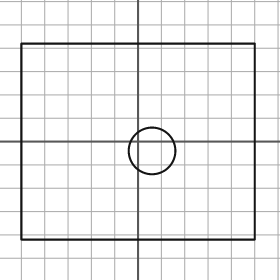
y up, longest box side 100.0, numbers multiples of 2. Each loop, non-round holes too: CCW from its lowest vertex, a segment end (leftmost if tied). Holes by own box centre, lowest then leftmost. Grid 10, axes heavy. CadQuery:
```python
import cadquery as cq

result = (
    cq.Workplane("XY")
    .moveTo(-50.0, -42.0)
    .lineTo(50.0, -42.0)
    .lineTo(50.0, 42.0)
    .lineTo(-50.0, 42.0)
    .close()
    .moveTo(6.0, -4.0)
    .circle(10.0)
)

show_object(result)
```